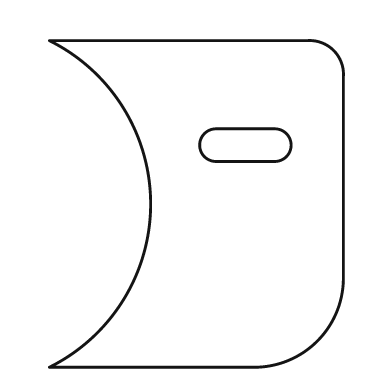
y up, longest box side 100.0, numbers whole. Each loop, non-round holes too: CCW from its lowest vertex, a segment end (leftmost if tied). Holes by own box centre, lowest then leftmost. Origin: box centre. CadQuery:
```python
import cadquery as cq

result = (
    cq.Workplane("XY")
    .moveTo(-45.0, -50.0)
    .lineTo(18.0, -50.0)
    .threePointArc((37.0, -42.0), (45.0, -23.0))
    .lineTo(45.0, 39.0)
    .threePointArc((42.0, 47.0), (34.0, 50.0))
    .lineTo(-45.0, 50.0)
    .threePointArc((-14.0, 0.0), (-45.0, -50.0))
    .close()
    .moveTo(6.0, 13.0)
    .lineTo(24.0, 13.0)
    .threePointArc((29.0, 18.0), (24.0, 23.0))
    .lineTo(6.0, 23.0)
    .threePointArc((1.0, 18.0), (6.0, 13.0))
    .close()
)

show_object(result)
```